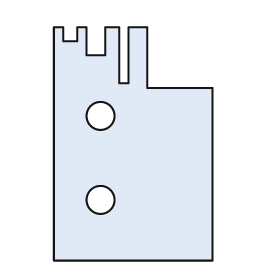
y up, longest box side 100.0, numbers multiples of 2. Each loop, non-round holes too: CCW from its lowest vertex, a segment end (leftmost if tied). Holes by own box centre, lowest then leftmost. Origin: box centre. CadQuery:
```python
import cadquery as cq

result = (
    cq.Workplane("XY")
    .moveTo(-34.0, -50.0)
    .lineTo(34.0, -50.0)
    .lineTo(34.0, 24.0)
    .lineTo(6.0, 24.0)
    .lineTo(6.0, 50.0)
    .lineTo(-2.0, 50.0)
    .lineTo(-2.0, 26.0)
    .lineTo(-6.0, 26.0)
    .lineTo(-6.0, 50.0)
    .lineTo(-12.0, 50.0)
    .lineTo(-12.0, 38.0)
    .lineTo(-20.0, 38.0)
    .lineTo(-20.0, 50.0)
    .lineTo(-24.0, 50.0)
    .lineTo(-24.0, 44.0)
    .lineTo(-30.0, 44.0)
    .lineTo(-30.0, 50.0)
    .lineTo(-34.0, 50.0)
    .close()
    .moveTo(-14.0, -24.0)
    .circle(6.0)
    .moveTo(-14.0, 12.0)
    .circle(6.0)
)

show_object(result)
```